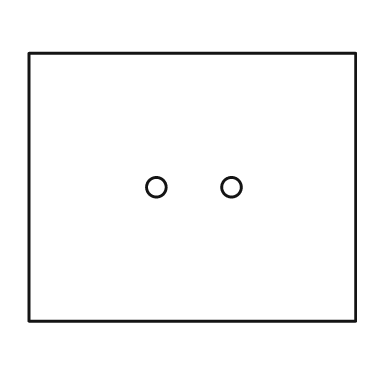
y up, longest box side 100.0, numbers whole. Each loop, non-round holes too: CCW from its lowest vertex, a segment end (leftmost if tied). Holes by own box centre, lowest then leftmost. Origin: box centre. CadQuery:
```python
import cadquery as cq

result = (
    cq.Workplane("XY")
    .moveTo(-50.0, -41.0)
    .lineTo(50.0, -41.0)
    .lineTo(50.0, 41.0)
    .lineTo(-50.0, 41.0)
    .close()
    .moveTo(-11.0, 0.0)
    .circle(3.0)
    .moveTo(12.0, 0.0)
    .circle(3.0)
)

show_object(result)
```